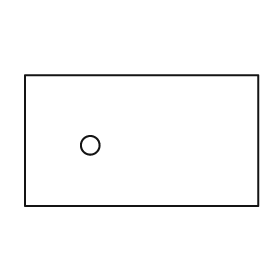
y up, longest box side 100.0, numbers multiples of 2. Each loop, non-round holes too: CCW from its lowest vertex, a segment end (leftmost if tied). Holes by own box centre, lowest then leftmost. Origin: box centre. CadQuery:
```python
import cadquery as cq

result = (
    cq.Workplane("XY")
    .moveTo(-50.0, -28.0)
    .lineTo(50.0, -28.0)
    .lineTo(50.0, 28.0)
    .lineTo(-50.0, 28.0)
    .close()
    .moveTo(-22.0, -2.0)
    .circle(4.0)
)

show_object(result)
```